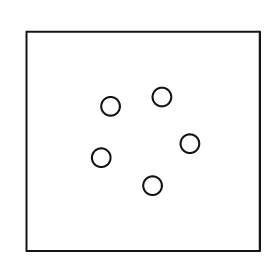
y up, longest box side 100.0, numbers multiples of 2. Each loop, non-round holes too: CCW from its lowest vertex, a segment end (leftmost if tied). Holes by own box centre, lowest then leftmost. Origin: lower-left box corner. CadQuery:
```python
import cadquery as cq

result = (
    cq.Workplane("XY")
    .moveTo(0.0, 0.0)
    .lineTo(100.0, 0.0)
    .lineTo(100.0, 94.0)
    .lineTo(0.0, 94.0)
    .close()
    .moveTo(54.0, 28.0)
    .circle(4.0)
    .moveTo(32.0, 40.0)
    .circle(4.0)
    .moveTo(70.0, 46.0)
    .circle(4.0)
    .moveTo(36.0, 62.0)
    .circle(4.0)
    .moveTo(58.0, 66.0)
    .circle(4.0)
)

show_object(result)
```